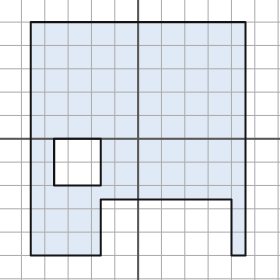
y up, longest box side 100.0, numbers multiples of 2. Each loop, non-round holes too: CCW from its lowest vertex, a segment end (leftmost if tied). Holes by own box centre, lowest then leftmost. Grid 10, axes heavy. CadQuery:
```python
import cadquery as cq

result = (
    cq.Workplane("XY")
    .moveTo(-46.0, -50.0)
    .lineTo(-16.0, -50.0)
    .lineTo(-16.0, -26.0)
    .lineTo(40.0, -26.0)
    .lineTo(40.0, -50.0)
    .lineTo(46.0, -50.0)
    .lineTo(46.0, 50.0)
    .lineTo(-46.0, 50.0)
    .close()
    .moveTo(-36.0, -20.0)
    .lineTo(-16.0, -20.0)
    .lineTo(-16.0, 0.0)
    .lineTo(-36.0, 0.0)
    .close()
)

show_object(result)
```